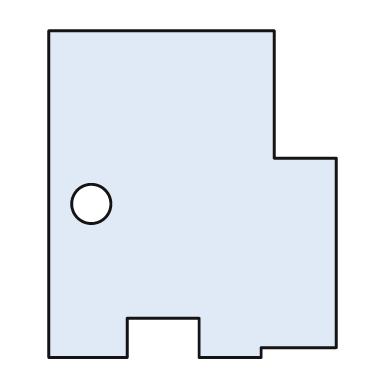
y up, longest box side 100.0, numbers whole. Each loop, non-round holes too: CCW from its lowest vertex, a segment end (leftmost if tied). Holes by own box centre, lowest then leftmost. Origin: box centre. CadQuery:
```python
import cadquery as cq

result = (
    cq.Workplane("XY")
    .moveTo(-44.0, -50.0)
    .lineTo(-20.0, -50.0)
    .lineTo(-20.0, -38.0)
    .lineTo(2.0, -38.0)
    .lineTo(2.0, -50.0)
    .lineTo(21.0, -50.0)
    .lineTo(21.0, -47.0)
    .lineTo(44.0, -47.0)
    .lineTo(44.0, 11.0)
    .lineTo(25.0, 11.0)
    .lineTo(25.0, 50.0)
    .lineTo(-44.0, 50.0)
    .close()
    .moveTo(-31.0, -3.0)
    .circle(6.0)
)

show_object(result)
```